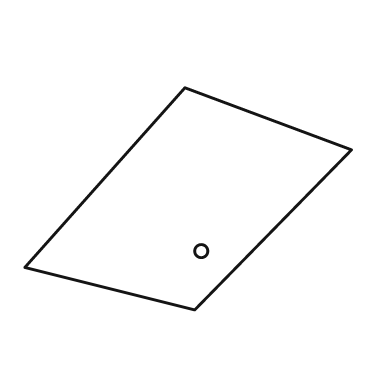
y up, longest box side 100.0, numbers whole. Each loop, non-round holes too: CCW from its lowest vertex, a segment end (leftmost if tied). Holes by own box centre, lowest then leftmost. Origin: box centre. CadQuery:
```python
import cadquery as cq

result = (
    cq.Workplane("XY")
    .moveTo(2.0, -34.0)
    .lineTo(50.0, 15.0)
    .lineTo(-1.0, 34.0)
    .lineTo(-50.0, -21.0)
    .close()
    .moveTo(4.0, -16.0)
    .circle(2.0)
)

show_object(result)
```